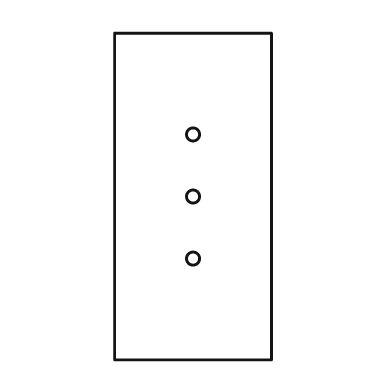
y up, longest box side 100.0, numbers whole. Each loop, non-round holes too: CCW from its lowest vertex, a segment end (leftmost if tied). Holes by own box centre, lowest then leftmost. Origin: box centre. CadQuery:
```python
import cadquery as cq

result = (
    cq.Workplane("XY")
    .moveTo(-24.0, -50.0)
    .lineTo(24.0, -50.0)
    .lineTo(24.0, 50.0)
    .lineTo(-24.0, 50.0)
    .close()
    .moveTo(0.0, -19.0)
    .circle(2.0)
    .moveTo(0.0, 0.0)
    .circle(2.0)
    .moveTo(0.0, 19.0)
    .circle(2.0)
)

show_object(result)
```